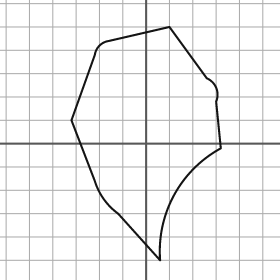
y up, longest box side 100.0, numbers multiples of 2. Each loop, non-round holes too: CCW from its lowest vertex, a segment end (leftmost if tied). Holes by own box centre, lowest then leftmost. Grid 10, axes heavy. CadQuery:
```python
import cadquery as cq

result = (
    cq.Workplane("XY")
    .moveTo(6.0, -50.0)
    .threePointArc((12.0, -22.0), (32.0, -2.0))
    .lineTo(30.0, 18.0)
    .threePointArc((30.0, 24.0), (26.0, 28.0))
    .lineTo(10.0, 50.0)
    .lineTo(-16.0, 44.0)
    .threePointArc((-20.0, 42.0), (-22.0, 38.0))
    .lineTo(-32.0, 10.0)
    .lineTo(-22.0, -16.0)
    .threePointArc((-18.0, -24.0), (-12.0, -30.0))
    .close()
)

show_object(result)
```